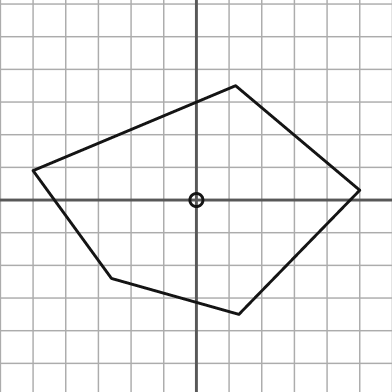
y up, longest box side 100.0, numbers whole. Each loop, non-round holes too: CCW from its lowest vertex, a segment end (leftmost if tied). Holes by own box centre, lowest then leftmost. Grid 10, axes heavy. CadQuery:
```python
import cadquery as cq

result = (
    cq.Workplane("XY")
    .moveTo(13.0, -35.0)
    .lineTo(50.0, 3.0)
    .lineTo(12.0, 35.0)
    .lineTo(-50.0, 9.0)
    .lineTo(-26.0, -24.0)
    .close()
    .moveTo(0.0, 0.0)
    .circle(2.0)
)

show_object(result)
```